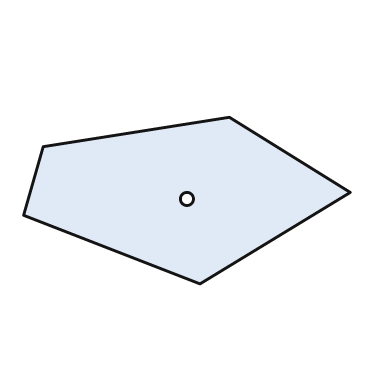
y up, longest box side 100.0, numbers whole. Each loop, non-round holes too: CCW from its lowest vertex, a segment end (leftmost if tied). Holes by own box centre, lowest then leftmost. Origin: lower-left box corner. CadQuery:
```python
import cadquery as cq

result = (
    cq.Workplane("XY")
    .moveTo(54.0, 0.0)
    .lineTo(100.0, 28.0)
    .lineTo(63.0, 51.0)
    .lineTo(6.0, 42.0)
    .lineTo(0.0, 21.0)
    .close()
    .moveTo(50.0, 26.0)
    .circle(2.0)
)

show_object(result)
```